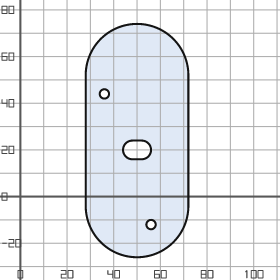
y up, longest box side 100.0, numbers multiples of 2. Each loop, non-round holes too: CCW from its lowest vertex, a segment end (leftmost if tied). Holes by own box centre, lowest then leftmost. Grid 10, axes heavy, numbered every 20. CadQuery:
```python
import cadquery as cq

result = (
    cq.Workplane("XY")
    .moveTo(28.0, -4.0)
    .threePointArc((50.0, -26.0), (72.0, -4.0))
    .lineTo(72.0, 52.0)
    .threePointArc((50.0, 74.0), (28.0, 52.0))
    .close()
    .moveTo(56.0, -12.0)
    .circle(2.0)
    .moveTo(48.0, 16.0)
    .lineTo(52.0, 16.0)
    .threePointArc((56.0, 20.0), (52.0, 24.0))
    .lineTo(48.0, 24.0)
    .threePointArc((44.0, 20.0), (48.0, 16.0))
    .close()
    .moveTo(36.0, 44.0)
    .circle(2.0)
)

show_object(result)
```